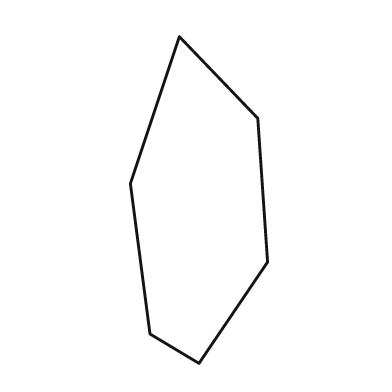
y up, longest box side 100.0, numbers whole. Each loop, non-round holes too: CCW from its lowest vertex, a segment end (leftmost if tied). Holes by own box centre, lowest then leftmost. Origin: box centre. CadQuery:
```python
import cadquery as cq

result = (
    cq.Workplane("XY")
    .moveTo(0.0, -50.0)
    .lineTo(21.0, -19.0)
    .lineTo(18.0, 25.0)
    .lineTo(-6.0, 50.0)
    .lineTo(-21.0, 5.0)
    .lineTo(-15.0, -41.0)
    .close()
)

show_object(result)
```